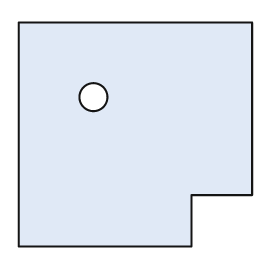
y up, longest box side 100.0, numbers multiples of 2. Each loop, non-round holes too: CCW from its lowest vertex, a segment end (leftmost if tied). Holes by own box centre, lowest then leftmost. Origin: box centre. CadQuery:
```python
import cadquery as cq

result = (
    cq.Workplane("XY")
    .moveTo(-50.0, -48.0)
    .lineTo(24.0, -48.0)
    .lineTo(24.0, -26.0)
    .lineTo(50.0, -26.0)
    .lineTo(50.0, 48.0)
    .lineTo(-50.0, 48.0)
    .close()
    .moveTo(-18.0, 16.0)
    .circle(6.0)
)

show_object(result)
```